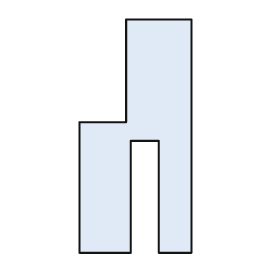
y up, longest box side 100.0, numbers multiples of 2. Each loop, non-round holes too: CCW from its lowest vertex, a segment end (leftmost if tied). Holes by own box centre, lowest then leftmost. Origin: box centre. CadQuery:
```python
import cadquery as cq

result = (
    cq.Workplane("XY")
    .moveTo(-24.0, -50.0)
    .lineTo(-2.0, -50.0)
    .lineTo(-2.0, -2.0)
    .lineTo(10.0, -2.0)
    .lineTo(10.0, -50.0)
    .lineTo(24.0, -50.0)
    .lineTo(24.0, 50.0)
    .lineTo(-4.0, 50.0)
    .lineTo(-4.0, 6.0)
    .lineTo(-24.0, 6.0)
    .close()
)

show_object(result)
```